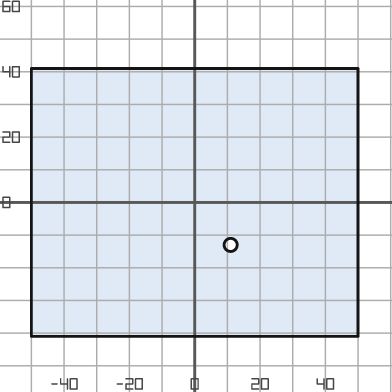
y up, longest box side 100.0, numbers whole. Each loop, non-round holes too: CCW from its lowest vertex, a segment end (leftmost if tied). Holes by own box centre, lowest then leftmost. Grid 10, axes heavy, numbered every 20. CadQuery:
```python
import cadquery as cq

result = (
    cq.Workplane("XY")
    .moveTo(-50.0, -41.0)
    .lineTo(50.0, -41.0)
    .lineTo(50.0, 41.0)
    .lineTo(-50.0, 41.0)
    .close()
    .moveTo(11.0, -13.0)
    .circle(2.0)
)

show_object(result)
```